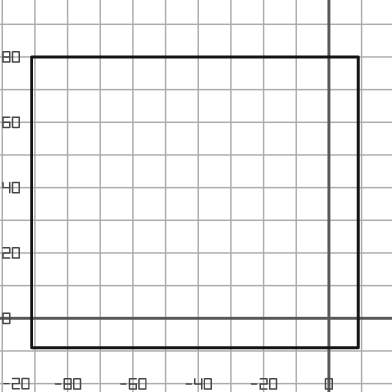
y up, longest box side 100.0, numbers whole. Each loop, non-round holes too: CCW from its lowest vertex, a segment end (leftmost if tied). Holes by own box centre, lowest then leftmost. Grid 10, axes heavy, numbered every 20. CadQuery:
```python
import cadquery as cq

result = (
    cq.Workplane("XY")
    .moveTo(-91.0, -9.0)
    .lineTo(9.0, -9.0)
    .lineTo(9.0, 80.0)
    .lineTo(-91.0, 80.0)
    .close()
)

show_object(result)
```